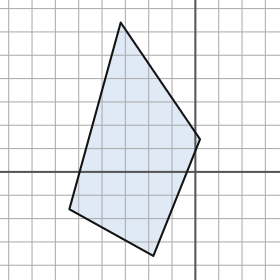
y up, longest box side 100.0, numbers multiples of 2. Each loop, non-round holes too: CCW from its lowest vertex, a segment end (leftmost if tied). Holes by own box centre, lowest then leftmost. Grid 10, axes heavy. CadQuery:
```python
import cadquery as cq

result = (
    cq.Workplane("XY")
    .moveTo(-18.0, -36.0)
    .lineTo(2.0, 14.0)
    .lineTo(-32.0, 64.0)
    .lineTo(-54.0, -16.0)
    .close()
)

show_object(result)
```